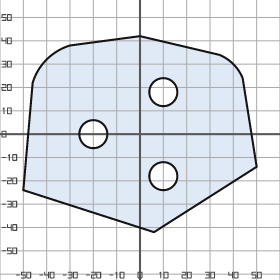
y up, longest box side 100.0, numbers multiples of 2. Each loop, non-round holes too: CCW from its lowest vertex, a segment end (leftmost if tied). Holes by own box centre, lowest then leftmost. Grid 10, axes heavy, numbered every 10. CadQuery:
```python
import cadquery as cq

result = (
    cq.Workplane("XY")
    .moveTo(6.0, -42.0)
    .lineTo(50.0, -14.0)
    .lineTo(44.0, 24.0)
    .threePointArc((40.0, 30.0), (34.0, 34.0))
    .lineTo(0.0, 42.0)
    .lineTo(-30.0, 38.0)
    .threePointArc((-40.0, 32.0), (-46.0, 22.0))
    .lineTo(-50.0, -24.0)
    .close()
    .moveTo(10.0, -18.0)
    .circle(6.0)
    .moveTo(-20.0, 0.0)
    .circle(6.0)
    .moveTo(10.0, 18.0)
    .circle(6.0)
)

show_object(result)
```